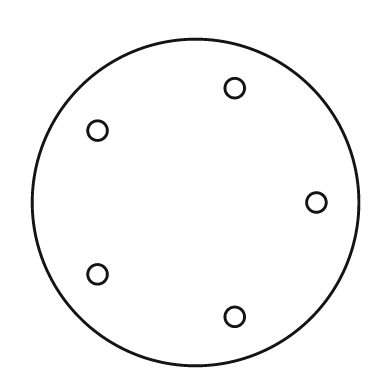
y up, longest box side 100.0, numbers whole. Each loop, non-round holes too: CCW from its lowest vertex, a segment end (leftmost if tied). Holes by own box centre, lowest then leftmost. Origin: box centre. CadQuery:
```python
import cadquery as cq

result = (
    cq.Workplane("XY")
    .moveTo(0.0, 0.0)
    .circle(50.0)
    .moveTo(12.0, -35.0)
    .circle(3.0)
    .moveTo(-30.0, -22.0)
    .circle(3.0)
    .moveTo(37.0, 0.0)
    .circle(3.0)
    .moveTo(-30.0, 22.0)
    .circle(3.0)
    .moveTo(12.0, 35.0)
    .circle(3.0)
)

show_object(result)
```